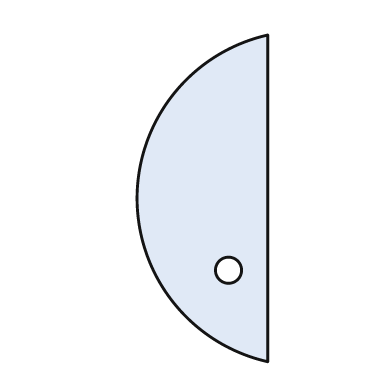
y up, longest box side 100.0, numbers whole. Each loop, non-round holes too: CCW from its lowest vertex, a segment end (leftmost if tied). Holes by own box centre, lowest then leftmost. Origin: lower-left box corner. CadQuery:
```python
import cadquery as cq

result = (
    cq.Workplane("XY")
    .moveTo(40.0, 0.0)
    .lineTo(40.0, 100.0)
    .threePointArc((0.0, 50.0), (40.0, 0.0))
    .close()
    .moveTo(28.0, 28.0)
    .circle(4.0)
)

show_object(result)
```